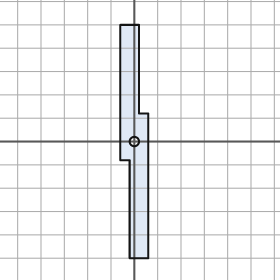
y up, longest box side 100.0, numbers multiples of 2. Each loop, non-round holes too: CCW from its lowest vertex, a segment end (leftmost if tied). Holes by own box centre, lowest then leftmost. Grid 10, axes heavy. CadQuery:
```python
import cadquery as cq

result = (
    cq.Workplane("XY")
    .moveTo(-2.0, -50.0)
    .lineTo(6.0, -50.0)
    .lineTo(6.0, 12.0)
    .lineTo(2.0, 12.0)
    .lineTo(2.0, 50.0)
    .lineTo(-6.0, 50.0)
    .lineTo(-6.0, -8.0)
    .lineTo(-2.0, -8.0)
    .close()
    .moveTo(0.0, 0.0)
    .circle(2.0)
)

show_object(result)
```